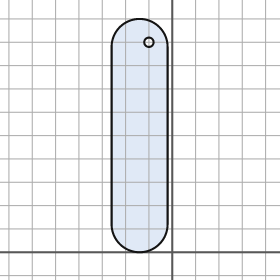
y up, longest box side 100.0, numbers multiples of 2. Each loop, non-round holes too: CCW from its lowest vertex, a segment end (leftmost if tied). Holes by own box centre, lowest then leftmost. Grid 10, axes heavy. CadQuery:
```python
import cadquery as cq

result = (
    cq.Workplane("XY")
    .moveTo(-26.0, 12.0)
    .threePointArc((-14.0, 0.0), (-2.0, 12.0))
    .lineTo(-2.0, 88.0)
    .threePointArc((-14.0, 100.0), (-26.0, 88.0))
    .close()
    .moveTo(-10.0, 90.0)
    .circle(2.0)
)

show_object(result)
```